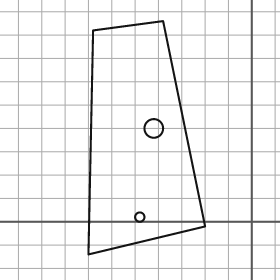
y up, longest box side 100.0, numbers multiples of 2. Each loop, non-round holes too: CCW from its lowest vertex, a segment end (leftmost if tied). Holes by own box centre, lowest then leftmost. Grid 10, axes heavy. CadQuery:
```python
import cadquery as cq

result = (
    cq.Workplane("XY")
    .moveTo(-70.0, -14.0)
    .lineTo(-20.0, -2.0)
    .lineTo(-38.0, 86.0)
    .lineTo(-68.0, 82.0)
    .close()
    .moveTo(-48.0, 2.0)
    .circle(2.0)
    .moveTo(-42.0, 40.0)
    .circle(4.0)
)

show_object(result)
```